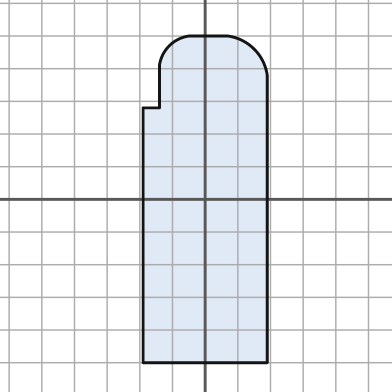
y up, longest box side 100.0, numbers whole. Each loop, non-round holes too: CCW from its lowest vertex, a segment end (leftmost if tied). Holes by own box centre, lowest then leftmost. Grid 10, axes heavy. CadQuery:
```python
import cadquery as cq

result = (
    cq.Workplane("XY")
    .moveTo(-19.0, -50.0)
    .lineTo(19.0, -50.0)
    .lineTo(19.0, 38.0)
    .threePointArc((15.0, 46.0), (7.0, 50.0))
    .lineTo(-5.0, 50.0)
    .threePointArc((-11.0, 47.0), (-14.0, 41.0))
    .lineTo(-14.0, 28.0)
    .lineTo(-19.0, 28.0)
    .close()
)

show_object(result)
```